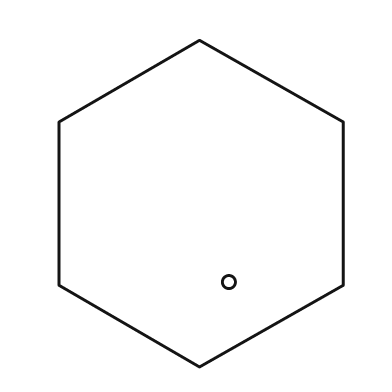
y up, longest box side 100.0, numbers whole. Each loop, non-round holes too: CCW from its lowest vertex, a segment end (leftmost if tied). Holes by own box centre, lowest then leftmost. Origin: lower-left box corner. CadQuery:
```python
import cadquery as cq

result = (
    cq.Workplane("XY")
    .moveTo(43.0, 0.0)
    .lineTo(87.0, 25.0)
    .lineTo(87.0, 75.0)
    .lineTo(43.0, 100.0)
    .lineTo(0.0, 75.0)
    .lineTo(0.0, 25.0)
    .close()
    .moveTo(52.0, 26.0)
    .circle(2.0)
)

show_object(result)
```